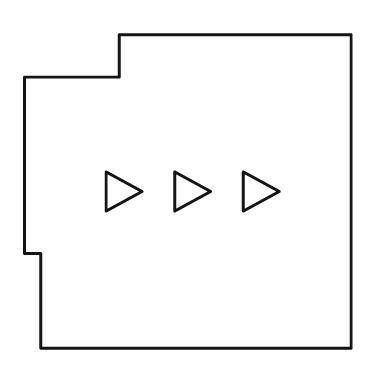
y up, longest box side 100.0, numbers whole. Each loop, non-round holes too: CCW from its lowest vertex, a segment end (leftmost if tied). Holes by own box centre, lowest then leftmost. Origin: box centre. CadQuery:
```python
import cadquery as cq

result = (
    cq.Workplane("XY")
    .moveTo(-45.0, -48.0)
    .lineTo(50.0, -48.0)
    .lineTo(50.0, 48.0)
    .lineTo(-21.0, 48.0)
    .lineTo(-21.0, 35.0)
    .lineTo(-50.0, 35.0)
    .lineTo(-50.0, -19.0)
    .lineTo(-45.0, -19.0)
    .close()
    .moveTo(-25.0, -6.0)
    .lineTo(-14.0, 0.0)
    .lineTo(-25.0, 6.0)
    .close()
    .moveTo(-4.0, -6.0)
    .lineTo(7.0, 0.0)
    .lineTo(-4.0, 6.0)
    .close()
    .moveTo(17.0, -6.0)
    .lineTo(28.0, 0.0)
    .lineTo(17.0, 6.0)
    .close()
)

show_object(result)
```